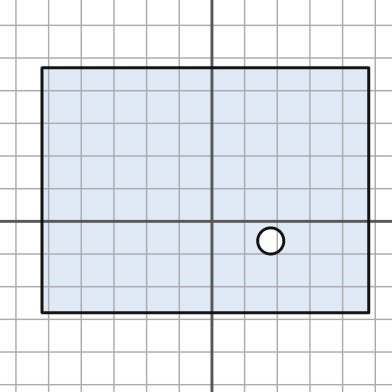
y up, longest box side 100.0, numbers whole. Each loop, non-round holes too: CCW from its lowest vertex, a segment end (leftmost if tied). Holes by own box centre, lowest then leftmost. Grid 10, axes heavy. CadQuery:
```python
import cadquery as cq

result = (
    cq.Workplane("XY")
    .moveTo(-52.0, -28.0)
    .lineTo(48.0, -28.0)
    .lineTo(48.0, 47.0)
    .lineTo(-52.0, 47.0)
    .close()
    .moveTo(18.0, -6.0)
    .circle(4.0)
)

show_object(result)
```